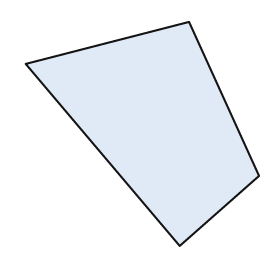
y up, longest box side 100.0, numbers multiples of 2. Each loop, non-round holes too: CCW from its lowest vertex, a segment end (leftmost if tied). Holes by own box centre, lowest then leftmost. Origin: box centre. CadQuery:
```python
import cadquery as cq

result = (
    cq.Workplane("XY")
    .moveTo(16.0, -48.0)
    .lineTo(50.0, -18.0)
    .lineTo(20.0, 48.0)
    .lineTo(-50.0, 30.0)
    .close()
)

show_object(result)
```